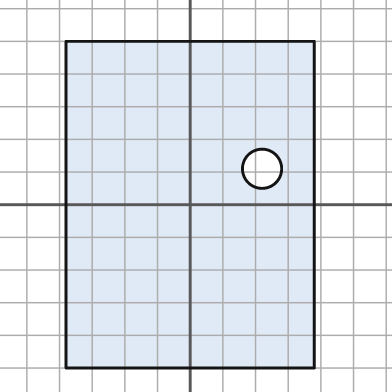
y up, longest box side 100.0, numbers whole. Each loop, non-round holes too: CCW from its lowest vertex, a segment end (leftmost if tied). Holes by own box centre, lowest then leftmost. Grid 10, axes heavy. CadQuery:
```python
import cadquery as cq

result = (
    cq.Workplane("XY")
    .moveTo(-38.0, -50.0)
    .lineTo(38.0, -50.0)
    .lineTo(38.0, 50.0)
    .lineTo(-38.0, 50.0)
    .close()
    .moveTo(22.0, 11.0)
    .circle(6.0)
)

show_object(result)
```